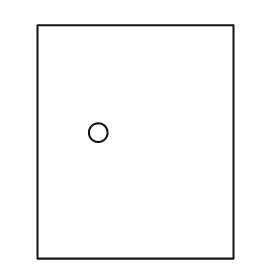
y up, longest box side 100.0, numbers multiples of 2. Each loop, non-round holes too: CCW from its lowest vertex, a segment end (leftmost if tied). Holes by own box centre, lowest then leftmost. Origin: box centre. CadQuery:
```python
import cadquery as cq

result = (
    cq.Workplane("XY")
    .moveTo(-42.0, -50.0)
    .lineTo(42.0, -50.0)
    .lineTo(42.0, 50.0)
    .lineTo(-42.0, 50.0)
    .close()
    .moveTo(-16.0, 4.0)
    .circle(4.0)
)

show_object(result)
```